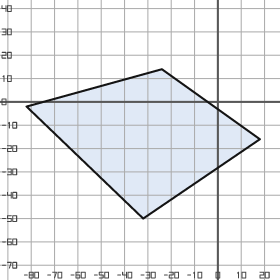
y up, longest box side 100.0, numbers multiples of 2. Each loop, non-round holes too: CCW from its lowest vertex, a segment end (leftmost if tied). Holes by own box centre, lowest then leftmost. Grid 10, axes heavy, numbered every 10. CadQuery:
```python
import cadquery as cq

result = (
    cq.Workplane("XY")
    .moveTo(-32.0, -50.0)
    .lineTo(18.0, -16.0)
    .lineTo(-24.0, 14.0)
    .lineTo(-82.0, -2.0)
    .close()
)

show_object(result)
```